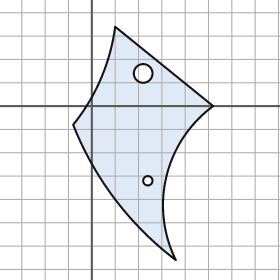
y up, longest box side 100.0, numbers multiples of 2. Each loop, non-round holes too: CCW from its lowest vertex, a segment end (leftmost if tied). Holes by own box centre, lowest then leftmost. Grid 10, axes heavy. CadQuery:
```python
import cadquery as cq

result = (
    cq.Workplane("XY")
    .moveTo(36.0, -66.0)
    .threePointArc((32.0, -30.0), (52.0, 0.0))
    .lineTo(10.0, 34.0)
    .threePointArc((4.0, 12.0), (-8.0, -8.0))
    .threePointArc((10.0, -40.0), (36.0, -66.0))
    .close()
    .moveTo(24.0, -32.0)
    .circle(2.0)
    .moveTo(22.0, 14.0)
    .circle(4.0)
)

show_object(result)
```